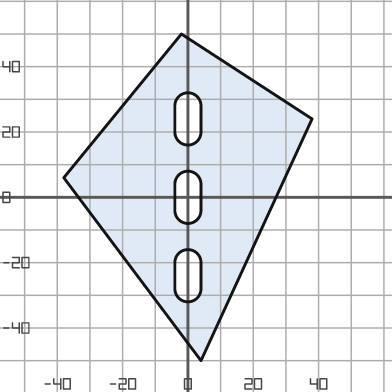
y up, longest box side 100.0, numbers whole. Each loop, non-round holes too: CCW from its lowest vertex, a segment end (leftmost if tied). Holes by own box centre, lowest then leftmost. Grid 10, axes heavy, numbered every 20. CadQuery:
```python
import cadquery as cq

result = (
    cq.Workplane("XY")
    .moveTo(4.0, -50.0)
    .lineTo(38.0, 24.0)
    .lineTo(-2.0, 50.0)
    .lineTo(-38.0, 6.0)
    .close()
    .moveTo(-4.0, -28.0)
    .threePointArc((0.0, -32.0), (4.0, -28.0))
    .lineTo(4.0, -20.0)
    .threePointArc((0.0, -16.0), (-4.0, -20.0))
    .close()
    .moveTo(-4.0, -4.0)
    .threePointArc((0.0, -8.0), (4.0, -4.0))
    .lineTo(4.0, 4.0)
    .threePointArc((0.0, 8.0), (-4.0, 4.0))
    .close()
    .moveTo(-4.0, 20.0)
    .threePointArc((0.0, 16.0), (4.0, 20.0))
    .lineTo(4.0, 28.0)
    .threePointArc((0.0, 32.0), (-4.0, 28.0))
    .close()
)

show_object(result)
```